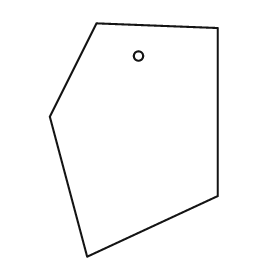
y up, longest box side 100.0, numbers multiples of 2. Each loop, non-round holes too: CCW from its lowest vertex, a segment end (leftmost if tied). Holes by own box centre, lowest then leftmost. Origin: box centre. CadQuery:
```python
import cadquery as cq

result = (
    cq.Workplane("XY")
    .moveTo(-20.0, -50.0)
    .lineTo(36.0, -24.0)
    .lineTo(36.0, 48.0)
    .lineTo(-16.0, 50.0)
    .lineTo(-36.0, 10.0)
    .close()
    .moveTo(2.0, 36.0)
    .circle(2.0)
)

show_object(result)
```